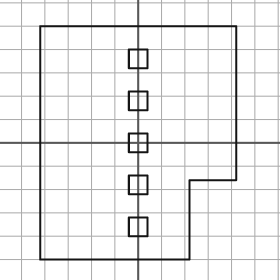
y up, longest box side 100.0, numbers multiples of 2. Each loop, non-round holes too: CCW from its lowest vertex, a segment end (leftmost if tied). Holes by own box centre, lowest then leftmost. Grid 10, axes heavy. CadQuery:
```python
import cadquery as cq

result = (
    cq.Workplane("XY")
    .moveTo(-42.0, -50.0)
    .lineTo(22.0, -50.0)
    .lineTo(22.0, -16.0)
    .lineTo(42.0, -16.0)
    .lineTo(42.0, 50.0)
    .lineTo(-42.0, 50.0)
    .close()
    .moveTo(-4.0, -40.0)
    .lineTo(4.0, -40.0)
    .lineTo(4.0, -32.0)
    .lineTo(-4.0, -32.0)
    .close()
    .moveTo(-4.0, -22.0)
    .lineTo(4.0, -22.0)
    .lineTo(4.0, -14.0)
    .lineTo(-4.0, -14.0)
    .close()
    .moveTo(-4.0, -4.0)
    .lineTo(4.0, -4.0)
    .lineTo(4.0, 4.0)
    .lineTo(-4.0, 4.0)
    .close()
    .moveTo(-4.0, 14.0)
    .lineTo(4.0, 14.0)
    .lineTo(4.0, 22.0)
    .lineTo(-4.0, 22.0)
    .close()
    .moveTo(-4.0, 32.0)
    .lineTo(4.0, 32.0)
    .lineTo(4.0, 40.0)
    .lineTo(-4.0, 40.0)
    .close()
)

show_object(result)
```